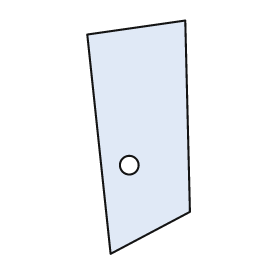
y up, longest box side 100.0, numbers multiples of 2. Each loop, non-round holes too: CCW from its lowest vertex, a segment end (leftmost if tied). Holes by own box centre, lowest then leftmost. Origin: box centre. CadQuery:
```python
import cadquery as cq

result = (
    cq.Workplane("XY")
    .moveTo(-12.0, -50.0)
    .lineTo(22.0, -32.0)
    .lineTo(20.0, 50.0)
    .lineTo(-22.0, 44.0)
    .close()
    .moveTo(-4.0, -12.0)
    .circle(4.0)
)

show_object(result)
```